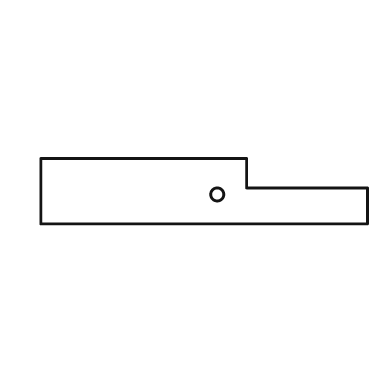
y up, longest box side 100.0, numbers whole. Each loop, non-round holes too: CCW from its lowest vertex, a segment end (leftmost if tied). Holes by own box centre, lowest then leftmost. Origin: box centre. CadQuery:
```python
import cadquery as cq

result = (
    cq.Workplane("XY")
    .moveTo(-50.0, -10.0)
    .lineTo(50.0, -10.0)
    .lineTo(50.0, 1.0)
    .lineTo(13.0, 1.0)
    .lineTo(13.0, 10.0)
    .lineTo(-50.0, 10.0)
    .close()
    .moveTo(4.0, -1.0)
    .circle(2.0)
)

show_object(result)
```